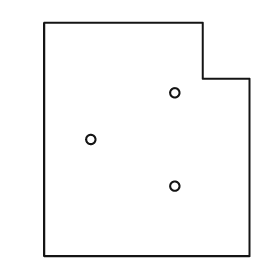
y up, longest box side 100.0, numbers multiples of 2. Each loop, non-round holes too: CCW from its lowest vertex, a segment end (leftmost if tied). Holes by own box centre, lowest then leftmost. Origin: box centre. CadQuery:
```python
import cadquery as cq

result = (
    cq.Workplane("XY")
    .moveTo(-44.0, -50.0)
    .lineTo(44.0, -50.0)
    .lineTo(44.0, 26.0)
    .lineTo(24.0, 26.0)
    .lineTo(24.0, 50.0)
    .lineTo(-44.0, 50.0)
    .close()
    .moveTo(12.0, -20.0)
    .circle(2.0)
    .moveTo(-24.0, 0.0)
    .circle(2.0)
    .moveTo(12.0, 20.0)
    .circle(2.0)
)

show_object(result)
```